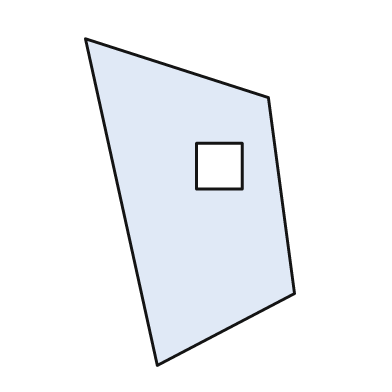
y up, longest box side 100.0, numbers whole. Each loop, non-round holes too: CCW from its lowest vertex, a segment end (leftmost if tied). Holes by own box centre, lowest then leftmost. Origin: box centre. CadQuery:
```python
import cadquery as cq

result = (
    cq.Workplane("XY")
    .moveTo(-10.0, -50.0)
    .lineTo(32.0, -28.0)
    .lineTo(24.0, 32.0)
    .lineTo(-32.0, 50.0)
    .close()
    .moveTo(2.0, 4.0)
    .lineTo(16.0, 4.0)
    .lineTo(16.0, 18.0)
    .lineTo(2.0, 18.0)
    .close()
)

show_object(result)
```